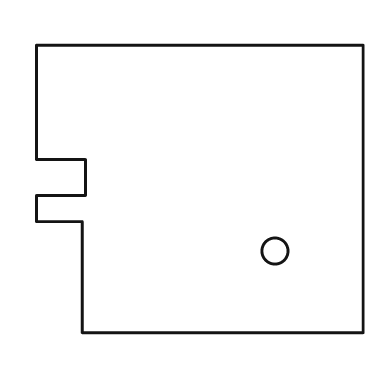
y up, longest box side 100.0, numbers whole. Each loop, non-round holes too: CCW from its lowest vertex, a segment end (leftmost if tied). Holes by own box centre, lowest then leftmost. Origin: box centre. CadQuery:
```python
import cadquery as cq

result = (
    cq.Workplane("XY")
    .moveTo(-36.0, -44.0)
    .lineTo(50.0, -44.0)
    .lineTo(50.0, 44.0)
    .lineTo(-50.0, 44.0)
    .lineTo(-50.0, 9.0)
    .lineTo(-35.0, 9.0)
    .lineTo(-35.0, -2.0)
    .lineTo(-50.0, -2.0)
    .lineTo(-50.0, -10.0)
    .lineTo(-36.0, -10.0)
    .close()
    .moveTo(23.0, -19.0)
    .circle(4.0)
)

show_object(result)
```